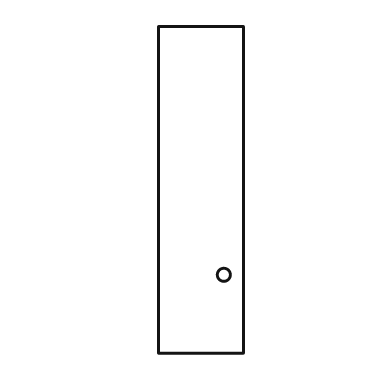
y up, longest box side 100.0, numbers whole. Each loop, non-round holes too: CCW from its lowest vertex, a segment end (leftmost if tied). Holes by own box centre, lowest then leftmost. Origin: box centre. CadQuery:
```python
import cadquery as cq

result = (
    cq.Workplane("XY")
    .moveTo(-13.0, -50.0)
    .lineTo(13.0, -50.0)
    .lineTo(13.0, 50.0)
    .lineTo(-13.0, 50.0)
    .close()
    .moveTo(7.0, -26.0)
    .circle(2.0)
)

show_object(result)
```